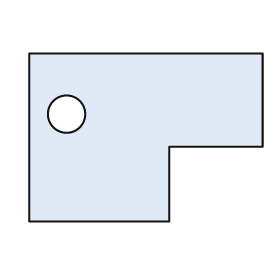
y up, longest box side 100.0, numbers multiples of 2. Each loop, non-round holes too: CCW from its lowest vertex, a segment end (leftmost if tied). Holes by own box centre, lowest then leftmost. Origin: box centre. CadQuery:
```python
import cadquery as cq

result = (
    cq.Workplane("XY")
    .moveTo(-50.0, -36.0)
    .lineTo(10.0, -36.0)
    .lineTo(10.0, -4.0)
    .lineTo(50.0, -4.0)
    .lineTo(50.0, 36.0)
    .lineTo(-50.0, 36.0)
    .close()
    .moveTo(-34.0, 10.0)
    .circle(8.0)
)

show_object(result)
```